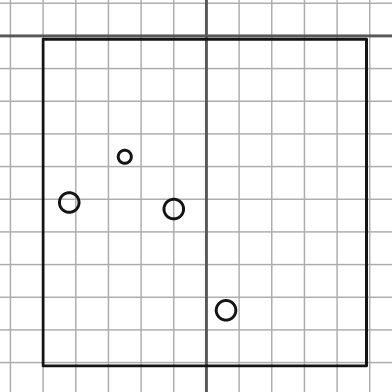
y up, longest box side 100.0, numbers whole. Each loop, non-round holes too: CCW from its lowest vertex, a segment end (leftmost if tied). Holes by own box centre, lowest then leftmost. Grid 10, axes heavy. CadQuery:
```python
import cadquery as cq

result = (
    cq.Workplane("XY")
    .moveTo(-50.0, -101.0)
    .lineTo(49.0, -101.0)
    .lineTo(49.0, -1.0)
    .lineTo(-50.0, -1.0)
    .close()
    .moveTo(6.0, -84.0)
    .circle(3.0)
    .moveTo(-10.0, -53.0)
    .circle(3.0)
    .moveTo(-42.0, -51.0)
    .circle(3.0)
    .moveTo(-25.0, -37.0)
    .circle(2.0)
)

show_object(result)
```